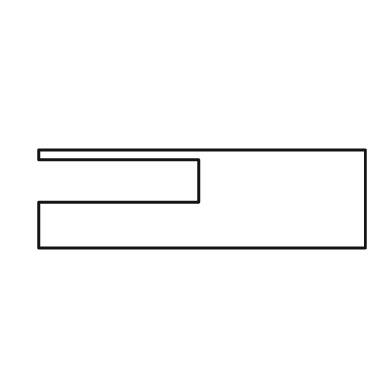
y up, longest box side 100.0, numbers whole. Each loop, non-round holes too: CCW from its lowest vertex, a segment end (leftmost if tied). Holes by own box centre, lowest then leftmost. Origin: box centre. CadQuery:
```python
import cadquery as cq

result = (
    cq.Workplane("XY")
    .moveTo(-50.0, -15.0)
    .lineTo(50.0, -15.0)
    .lineTo(50.0, 15.0)
    .lineTo(-50.0, 15.0)
    .lineTo(-50.0, 12.0)
    .lineTo(-1.0, 12.0)
    .lineTo(-1.0, -1.0)
    .lineTo(-50.0, -1.0)
    .close()
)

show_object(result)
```